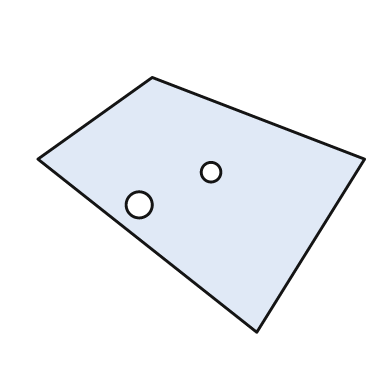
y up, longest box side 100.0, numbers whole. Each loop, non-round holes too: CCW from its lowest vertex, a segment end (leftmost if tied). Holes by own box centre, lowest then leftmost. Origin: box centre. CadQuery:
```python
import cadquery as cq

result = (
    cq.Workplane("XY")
    .moveTo(17.0, -39.0)
    .lineTo(50.0, 14.0)
    .lineTo(-15.0, 39.0)
    .lineTo(-50.0, 14.0)
    .close()
    .moveTo(-19.0, 0.0)
    .circle(4.0)
    .moveTo(3.0, 10.0)
    .circle(3.0)
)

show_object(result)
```